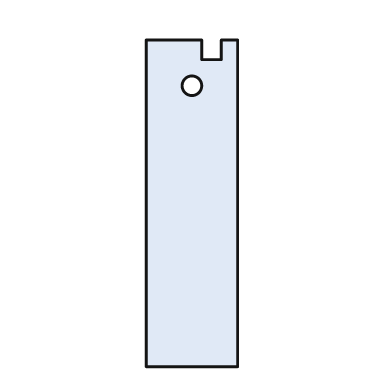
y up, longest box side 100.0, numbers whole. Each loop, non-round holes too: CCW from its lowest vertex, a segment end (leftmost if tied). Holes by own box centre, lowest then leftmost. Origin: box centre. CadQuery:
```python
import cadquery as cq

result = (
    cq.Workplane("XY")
    .moveTo(-14.0, -50.0)
    .lineTo(14.0, -50.0)
    .lineTo(14.0, 50.0)
    .lineTo(9.0, 50.0)
    .lineTo(9.0, 44.0)
    .lineTo(3.0, 44.0)
    .lineTo(3.0, 50.0)
    .lineTo(-14.0, 50.0)
    .close()
    .moveTo(0.0, 36.0)
    .circle(3.0)
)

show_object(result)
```